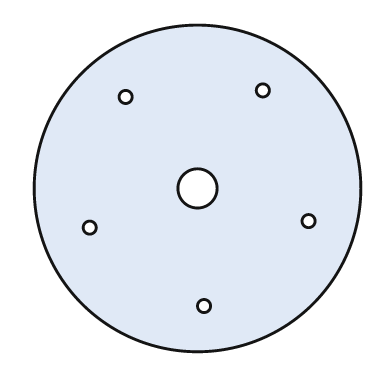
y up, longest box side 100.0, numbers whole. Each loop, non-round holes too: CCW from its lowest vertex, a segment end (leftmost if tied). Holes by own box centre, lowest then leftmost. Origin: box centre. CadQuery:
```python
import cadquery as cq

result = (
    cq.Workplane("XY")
    .moveTo(0.0, 0.0)
    .circle(50.0)
    .moveTo(2.0, -36.0)
    .circle(2.0)
    .moveTo(-33.0, -12.0)
    .circle(2.0)
    .moveTo(34.0, -10.0)
    .circle(2.0)
    .moveTo(0.0, 0.0)
    .circle(6.0)
    .moveTo(-22.0, 28.0)
    .circle(2.0)
    .moveTo(20.0, 30.0)
    .circle(2.0)
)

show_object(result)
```